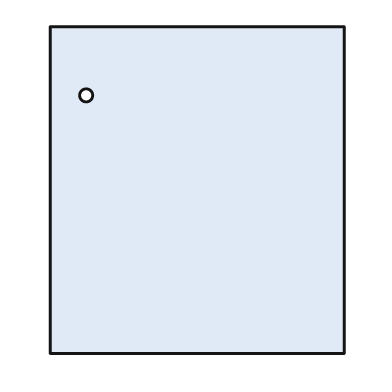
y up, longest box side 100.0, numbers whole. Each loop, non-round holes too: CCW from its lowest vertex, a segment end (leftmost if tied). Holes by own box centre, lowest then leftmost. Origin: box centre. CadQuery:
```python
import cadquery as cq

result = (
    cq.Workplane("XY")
    .moveTo(-45.0, -50.0)
    .lineTo(45.0, -50.0)
    .lineTo(45.0, 50.0)
    .lineTo(-45.0, 50.0)
    .close()
    .moveTo(-34.0, 29.0)
    .circle(2.0)
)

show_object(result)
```